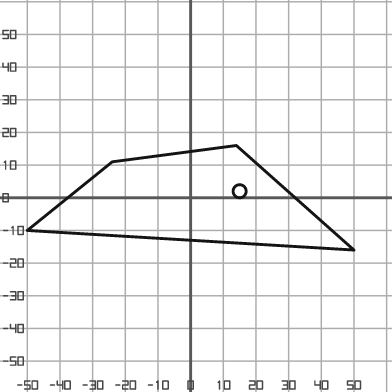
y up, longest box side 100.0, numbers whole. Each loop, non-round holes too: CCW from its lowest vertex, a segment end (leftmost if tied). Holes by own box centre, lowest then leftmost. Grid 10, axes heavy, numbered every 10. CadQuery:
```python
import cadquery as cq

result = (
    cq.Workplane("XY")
    .moveTo(50.0, -16.0)
    .lineTo(14.0, 16.0)
    .lineTo(-24.0, 11.0)
    .lineTo(-50.0, -10.0)
    .close()
    .moveTo(15.0, 2.0)
    .circle(2.0)
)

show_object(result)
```